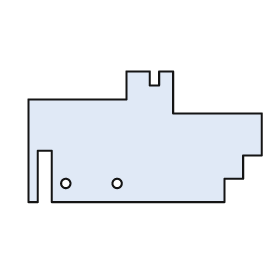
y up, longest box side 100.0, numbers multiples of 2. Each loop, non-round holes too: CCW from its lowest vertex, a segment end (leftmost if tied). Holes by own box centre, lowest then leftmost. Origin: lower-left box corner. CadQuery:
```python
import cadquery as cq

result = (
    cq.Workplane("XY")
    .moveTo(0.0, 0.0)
    .lineTo(4.0, 0.0)
    .lineTo(4.0, 22.0)
    .lineTo(10.0, 22.0)
    .lineTo(10.0, 0.0)
    .lineTo(84.0, 0.0)
    .lineTo(84.0, 10.0)
    .lineTo(92.0, 10.0)
    .lineTo(92.0, 20.0)
    .lineTo(100.0, 20.0)
    .lineTo(100.0, 38.0)
    .lineTo(62.0, 38.0)
    .lineTo(62.0, 56.0)
    .lineTo(56.0, 56.0)
    .lineTo(56.0, 50.0)
    .lineTo(52.0, 50.0)
    .lineTo(52.0, 56.0)
    .lineTo(42.0, 56.0)
    .lineTo(42.0, 44.0)
    .lineTo(0.0, 44.0)
    .close()
    .moveTo(16.0, 8.0)
    .circle(2.0)
    .moveTo(38.0, 8.0)
    .circle(2.0)
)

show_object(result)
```